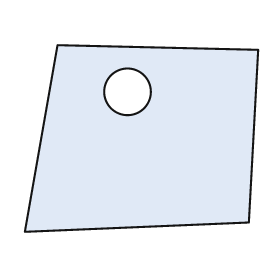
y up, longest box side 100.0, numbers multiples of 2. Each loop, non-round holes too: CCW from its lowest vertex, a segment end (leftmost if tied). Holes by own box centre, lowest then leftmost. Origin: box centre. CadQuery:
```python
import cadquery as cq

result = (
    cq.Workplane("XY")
    .moveTo(-50.0, -40.0)
    .lineTo(46.0, -36.0)
    .lineTo(50.0, 38.0)
    .lineTo(-36.0, 40.0)
    .close()
    .moveTo(-6.0, 20.0)
    .circle(10.0)
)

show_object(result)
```